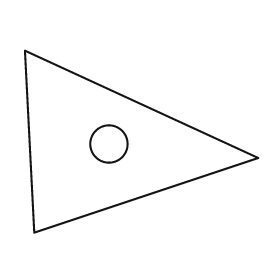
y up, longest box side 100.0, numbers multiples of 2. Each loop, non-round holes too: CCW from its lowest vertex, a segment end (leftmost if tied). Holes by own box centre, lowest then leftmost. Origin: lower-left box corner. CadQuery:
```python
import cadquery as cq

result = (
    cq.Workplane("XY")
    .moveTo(4.0, 0.0)
    .lineTo(100.0, 32.0)
    .lineTo(0.0, 78.0)
    .close()
    .moveTo(36.0, 38.0)
    .circle(8.0)
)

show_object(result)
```